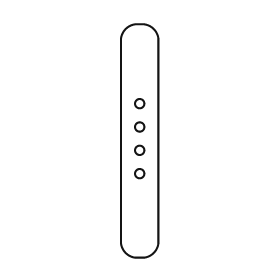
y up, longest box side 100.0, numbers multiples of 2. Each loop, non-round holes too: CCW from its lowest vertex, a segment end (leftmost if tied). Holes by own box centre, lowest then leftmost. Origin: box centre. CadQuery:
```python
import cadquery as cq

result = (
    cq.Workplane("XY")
    .moveTo(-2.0, -50.0)
    .lineTo(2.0, -50.0)
    .threePointArc((6.0, -48.0), (8.0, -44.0))
    .lineTo(8.0, 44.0)
    .threePointArc((6.0, 48.0), (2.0, 50.0))
    .lineTo(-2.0, 50.0)
    .threePointArc((-6.0, 48.0), (-8.0, 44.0))
    .lineTo(-8.0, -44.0)
    .threePointArc((-6.0, -48.0), (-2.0, -50.0))
    .close()
    .moveTo(0.0, -14.0)
    .circle(2.0)
    .moveTo(0.0, -4.0)
    .circle(2.0)
    .moveTo(0.0, 6.0)
    .circle(2.0)
    .moveTo(0.0, 16.0)
    .circle(2.0)
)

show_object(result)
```